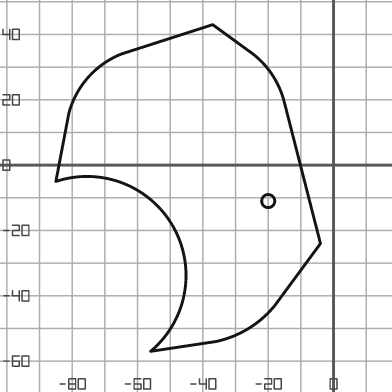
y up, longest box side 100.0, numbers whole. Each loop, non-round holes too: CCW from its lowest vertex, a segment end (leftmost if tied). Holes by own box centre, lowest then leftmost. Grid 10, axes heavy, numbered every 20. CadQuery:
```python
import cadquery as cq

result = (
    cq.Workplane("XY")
    .moveTo(-56.0, -57.0)
    .lineTo(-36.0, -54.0)
    .threePointArc((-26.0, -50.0), (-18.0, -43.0))
    .lineTo(-4.0, -24.0)
    .lineTo(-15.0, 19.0)
    .threePointArc((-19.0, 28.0), (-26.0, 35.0))
    .lineTo(-37.0, 43.0)
    .lineTo(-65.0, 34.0)
    .threePointArc((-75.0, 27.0), (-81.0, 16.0))
    .lineTo(-85.0, -5.0)
    .threePointArc((-49.0, -19.0), (-56.0, -57.0))
    .close()
    .moveTo(-20.0, -11.0)
    .circle(2.0)
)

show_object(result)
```